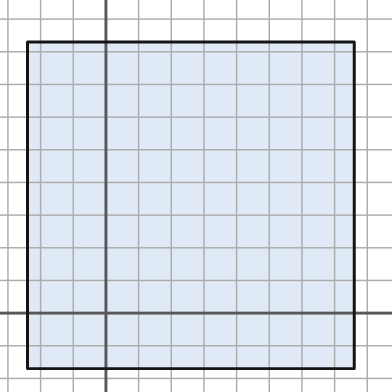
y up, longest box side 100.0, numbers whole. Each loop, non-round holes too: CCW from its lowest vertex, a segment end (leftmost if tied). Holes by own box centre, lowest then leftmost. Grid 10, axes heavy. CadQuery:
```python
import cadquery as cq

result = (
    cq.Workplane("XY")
    .moveTo(-24.0, -17.0)
    .lineTo(76.0, -17.0)
    .lineTo(76.0, 83.0)
    .lineTo(-24.0, 83.0)
    .close()
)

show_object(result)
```